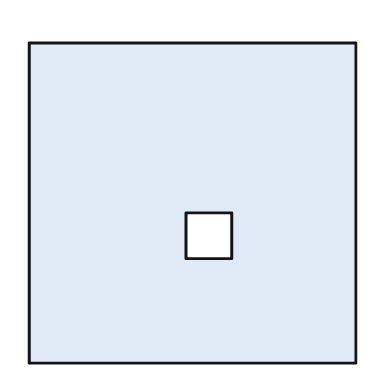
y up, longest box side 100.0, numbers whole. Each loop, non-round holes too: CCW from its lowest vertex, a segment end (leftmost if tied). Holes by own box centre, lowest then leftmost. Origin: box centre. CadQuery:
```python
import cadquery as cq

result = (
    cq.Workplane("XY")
    .moveTo(-50.0, -49.0)
    .lineTo(50.0, -49.0)
    .lineTo(50.0, 49.0)
    .lineTo(-50.0, 49.0)
    .close()
    .moveTo(-2.0, -17.0)
    .lineTo(12.0, -17.0)
    .lineTo(12.0, -3.0)
    .lineTo(-2.0, -3.0)
    .close()
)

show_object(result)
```